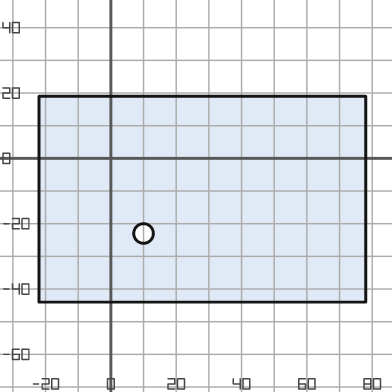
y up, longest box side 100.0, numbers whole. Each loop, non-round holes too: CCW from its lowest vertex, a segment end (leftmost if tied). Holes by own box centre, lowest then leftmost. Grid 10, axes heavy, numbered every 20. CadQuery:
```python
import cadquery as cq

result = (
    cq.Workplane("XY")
    .moveTo(-22.0, -44.0)
    .lineTo(78.0, -44.0)
    .lineTo(78.0, 19.0)
    .lineTo(-22.0, 19.0)
    .close()
    .moveTo(10.0, -23.0)
    .circle(3.0)
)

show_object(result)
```